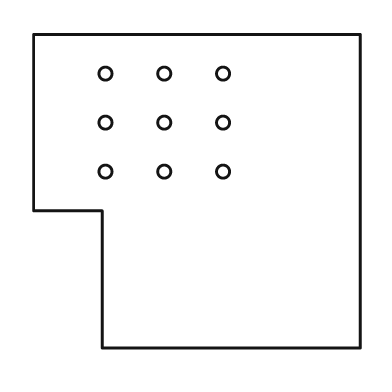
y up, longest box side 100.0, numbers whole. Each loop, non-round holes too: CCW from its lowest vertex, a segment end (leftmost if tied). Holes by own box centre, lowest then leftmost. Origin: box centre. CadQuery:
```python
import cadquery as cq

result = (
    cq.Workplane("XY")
    .moveTo(-29.0, -48.0)
    .lineTo(50.0, -48.0)
    .lineTo(50.0, 48.0)
    .lineTo(-50.0, 48.0)
    .lineTo(-50.0, -6.0)
    .lineTo(-29.0, -6.0)
    .close()
    .moveTo(-28.0, 6.0)
    .circle(2.0)
    .moveTo(-10.0, 6.0)
    .circle(2.0)
    .moveTo(8.0, 6.0)
    .circle(2.0)
    .moveTo(-28.0, 21.0)
    .circle(2.0)
    .moveTo(-10.0, 21.0)
    .circle(2.0)
    .moveTo(8.0, 21.0)
    .circle(2.0)
    .moveTo(-28.0, 36.0)
    .circle(2.0)
    .moveTo(-10.0, 36.0)
    .circle(2.0)
    .moveTo(8.0, 36.0)
    .circle(2.0)
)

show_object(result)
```